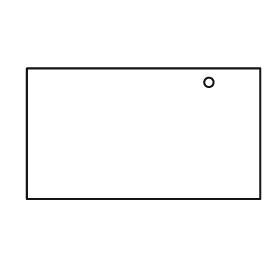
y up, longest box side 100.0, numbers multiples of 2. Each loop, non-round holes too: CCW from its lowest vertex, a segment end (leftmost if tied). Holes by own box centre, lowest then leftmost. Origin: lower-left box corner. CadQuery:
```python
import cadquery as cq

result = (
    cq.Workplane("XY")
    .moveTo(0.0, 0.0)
    .lineTo(100.0, 0.0)
    .lineTo(100.0, 56.0)
    .lineTo(0.0, 56.0)
    .close()
    .moveTo(78.0, 50.0)
    .circle(2.0)
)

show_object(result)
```